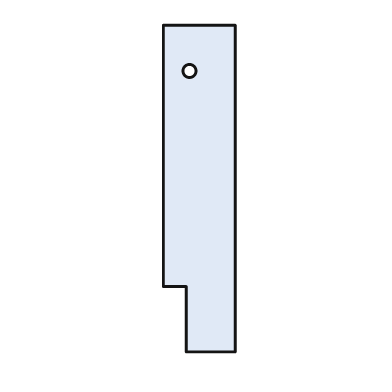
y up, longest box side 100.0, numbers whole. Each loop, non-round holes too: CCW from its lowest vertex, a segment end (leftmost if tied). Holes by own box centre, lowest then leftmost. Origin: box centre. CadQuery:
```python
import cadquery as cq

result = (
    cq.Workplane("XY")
    .moveTo(-4.0, -50.0)
    .lineTo(11.0, -50.0)
    .lineTo(11.0, 50.0)
    .lineTo(-11.0, 50.0)
    .lineTo(-11.0, -30.0)
    .lineTo(-4.0, -30.0)
    .close()
    .moveTo(-3.0, 36.0)
    .circle(2.0)
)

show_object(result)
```